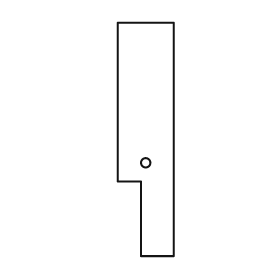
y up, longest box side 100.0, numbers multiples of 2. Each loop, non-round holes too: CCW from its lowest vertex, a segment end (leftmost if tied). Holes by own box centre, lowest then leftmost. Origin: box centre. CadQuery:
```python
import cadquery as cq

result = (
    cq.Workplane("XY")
    .moveTo(-2.0, -50.0)
    .lineTo(12.0, -50.0)
    .lineTo(12.0, 50.0)
    .lineTo(-12.0, 50.0)
    .lineTo(-12.0, -18.0)
    .lineTo(-2.0, -18.0)
    .close()
    .moveTo(0.0, -10.0)
    .circle(2.0)
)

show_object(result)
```